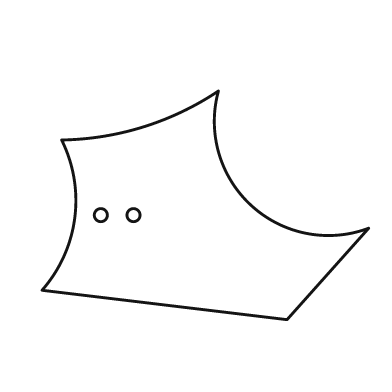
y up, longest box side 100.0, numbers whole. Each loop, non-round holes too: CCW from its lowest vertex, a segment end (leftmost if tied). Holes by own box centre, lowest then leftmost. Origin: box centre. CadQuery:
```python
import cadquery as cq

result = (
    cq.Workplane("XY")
    .moveTo(25.0, -35.0)
    .lineTo(50.0, -7.0)
    .threePointArc((14.0, 0.0), (4.0, 35.0))
    .threePointArc((-19.0, 24.0), (-44.0, 20.0))
    .threePointArc((-40.0, -4.0), (-50.0, -26.0))
    .close()
    .moveTo(-32.0, -3.0)
    .circle(2.0)
    .moveTo(-22.0, -3.0)
    .circle(2.0)
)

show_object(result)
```